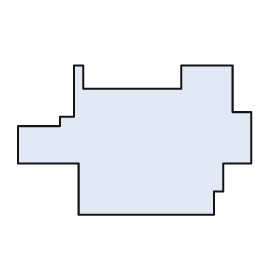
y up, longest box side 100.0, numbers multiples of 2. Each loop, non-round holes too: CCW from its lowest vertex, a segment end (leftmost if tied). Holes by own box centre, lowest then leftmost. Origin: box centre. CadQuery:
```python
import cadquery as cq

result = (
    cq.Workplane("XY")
    .moveTo(-24.0, -32.0)
    .lineTo(34.0, -32.0)
    .lineTo(34.0, -22.0)
    .lineTo(38.0, -22.0)
    .lineTo(38.0, -10.0)
    .lineTo(50.0, -10.0)
    .lineTo(50.0, 12.0)
    .lineTo(42.0, 12.0)
    .lineTo(42.0, 32.0)
    .lineTo(20.0, 32.0)
    .lineTo(20.0, 22.0)
    .lineTo(-22.0, 22.0)
    .lineTo(-22.0, 32.0)
    .lineTo(-26.0, 32.0)
    .lineTo(-26.0, 10.0)
    .lineTo(-32.0, 10.0)
    .lineTo(-32.0, 6.0)
    .lineTo(-50.0, 6.0)
    .lineTo(-50.0, -10.0)
    .lineTo(-24.0, -10.0)
    .close()
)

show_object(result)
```